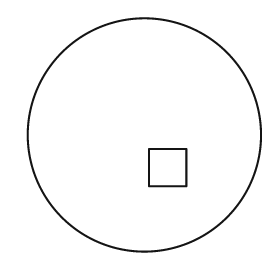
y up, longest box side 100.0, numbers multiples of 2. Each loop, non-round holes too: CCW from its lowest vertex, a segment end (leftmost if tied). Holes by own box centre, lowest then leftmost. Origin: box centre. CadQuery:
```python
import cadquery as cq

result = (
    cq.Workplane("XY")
    .moveTo(0.0, 0.0)
    .circle(50.0)
    .moveTo(2.0, -22.0)
    .lineTo(18.0, -22.0)
    .lineTo(18.0, -6.0)
    .lineTo(2.0, -6.0)
    .close()
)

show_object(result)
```